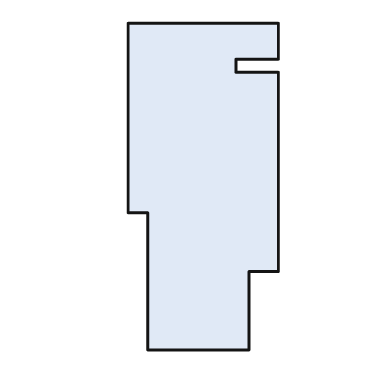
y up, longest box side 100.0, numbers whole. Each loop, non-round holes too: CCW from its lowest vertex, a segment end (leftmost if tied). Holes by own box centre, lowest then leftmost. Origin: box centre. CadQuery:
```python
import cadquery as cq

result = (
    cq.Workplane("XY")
    .moveTo(-17.0, -50.0)
    .lineTo(14.0, -50.0)
    .lineTo(14.0, -26.0)
    .lineTo(23.0, -26.0)
    .lineTo(23.0, 35.0)
    .lineTo(10.0, 35.0)
    .lineTo(10.0, 39.0)
    .lineTo(23.0, 39.0)
    .lineTo(23.0, 50.0)
    .lineTo(-23.0, 50.0)
    .lineTo(-23.0, -8.0)
    .lineTo(-17.0, -8.0)
    .close()
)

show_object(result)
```